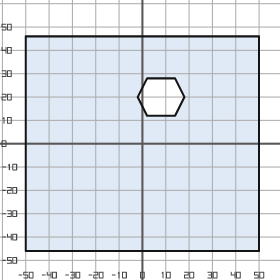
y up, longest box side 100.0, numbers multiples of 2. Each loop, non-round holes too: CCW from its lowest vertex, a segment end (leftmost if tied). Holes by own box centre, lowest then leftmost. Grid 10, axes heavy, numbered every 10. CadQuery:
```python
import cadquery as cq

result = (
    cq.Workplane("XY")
    .moveTo(-50.0, -46.0)
    .lineTo(50.0, -46.0)
    .lineTo(50.0, 46.0)
    .lineTo(-50.0, 46.0)
    .close()
    .moveTo(2.0, 12.0)
    .lineTo(14.0, 12.0)
    .lineTo(18.0, 20.0)
    .lineTo(14.0, 28.0)
    .lineTo(2.0, 28.0)
    .lineTo(-2.0, 20.0)
    .close()
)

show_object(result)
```